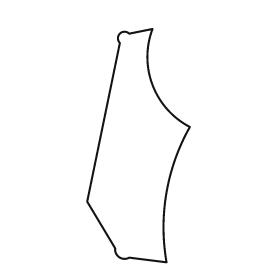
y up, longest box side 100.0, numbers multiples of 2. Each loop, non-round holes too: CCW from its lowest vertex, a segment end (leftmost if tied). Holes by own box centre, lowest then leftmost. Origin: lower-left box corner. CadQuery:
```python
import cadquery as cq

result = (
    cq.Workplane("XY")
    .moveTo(34.0, 0.0)
    .threePointArc((34.0, 30.0), (44.0, 58.0))
    .threePointArc((28.0, 76.0), (28.0, 100.0))
    .lineTo(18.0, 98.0)
    .threePointArc((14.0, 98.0), (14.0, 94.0))
    .lineTo(0.0, 26.0)
    .lineTo(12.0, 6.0)
    .threePointArc((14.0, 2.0), (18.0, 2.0))
    .close()
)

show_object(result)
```